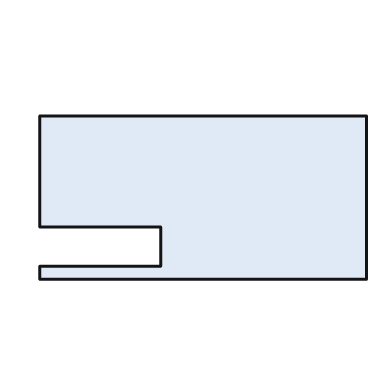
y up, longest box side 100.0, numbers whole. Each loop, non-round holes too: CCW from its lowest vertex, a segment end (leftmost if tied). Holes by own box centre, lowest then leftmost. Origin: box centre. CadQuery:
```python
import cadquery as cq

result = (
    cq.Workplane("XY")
    .moveTo(-50.0, -25.0)
    .lineTo(50.0, -25.0)
    .lineTo(50.0, 25.0)
    .lineTo(-50.0, 25.0)
    .lineTo(-50.0, -9.0)
    .lineTo(-13.0, -9.0)
    .lineTo(-13.0, -21.0)
    .lineTo(-50.0, -21.0)
    .close()
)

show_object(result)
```